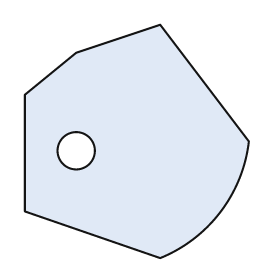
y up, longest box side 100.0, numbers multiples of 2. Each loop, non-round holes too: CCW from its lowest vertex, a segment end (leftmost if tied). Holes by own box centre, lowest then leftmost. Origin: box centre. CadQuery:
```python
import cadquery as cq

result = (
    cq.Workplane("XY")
    .moveTo(10.0, -50.0)
    .threePointArc((36.0, -30.0), (48.0, 0.0))
    .lineTo(10.0, 50.0)
    .lineTo(-26.0, 38.0)
    .lineTo(-48.0, 20.0)
    .lineTo(-48.0, -30.0)
    .close()
    .moveTo(-26.0, -4.0)
    .circle(8.0)
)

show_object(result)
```